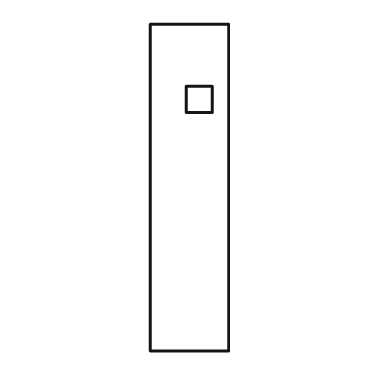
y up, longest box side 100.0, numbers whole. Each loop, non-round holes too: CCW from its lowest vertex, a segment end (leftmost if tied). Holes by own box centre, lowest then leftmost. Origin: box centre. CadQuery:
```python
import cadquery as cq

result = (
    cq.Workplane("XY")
    .moveTo(-12.0, -50.0)
    .lineTo(12.0, -50.0)
    .lineTo(12.0, 50.0)
    .lineTo(-12.0, 50.0)
    .close()
    .moveTo(-1.0, 23.0)
    .lineTo(7.0, 23.0)
    .lineTo(7.0, 31.0)
    .lineTo(-1.0, 31.0)
    .close()
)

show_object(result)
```